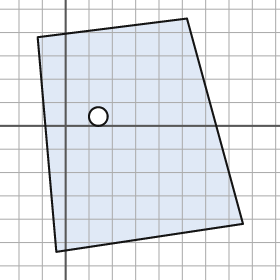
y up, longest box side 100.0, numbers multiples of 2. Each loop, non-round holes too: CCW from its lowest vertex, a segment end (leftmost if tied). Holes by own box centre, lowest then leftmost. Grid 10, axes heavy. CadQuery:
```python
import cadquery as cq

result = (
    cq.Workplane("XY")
    .moveTo(-4.0, -54.0)
    .lineTo(76.0, -42.0)
    .lineTo(52.0, 46.0)
    .lineTo(-12.0, 38.0)
    .close()
    .moveTo(14.0, 4.0)
    .circle(4.0)
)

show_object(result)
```